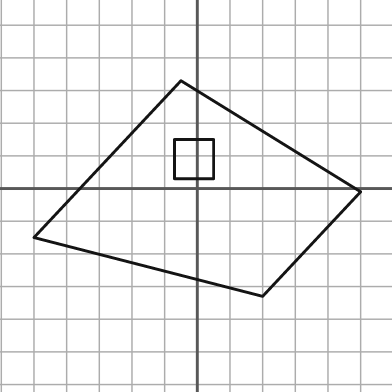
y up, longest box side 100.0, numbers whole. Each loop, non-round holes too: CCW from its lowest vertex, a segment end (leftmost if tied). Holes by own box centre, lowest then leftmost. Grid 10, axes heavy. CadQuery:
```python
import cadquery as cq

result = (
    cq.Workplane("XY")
    .moveTo(20.0, -33.0)
    .lineTo(50.0, -1.0)
    .lineTo(-5.0, 33.0)
    .lineTo(-50.0, -15.0)
    .close()
    .moveTo(-7.0, 3.0)
    .lineTo(5.0, 3.0)
    .lineTo(5.0, 15.0)
    .lineTo(-7.0, 15.0)
    .close()
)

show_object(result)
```